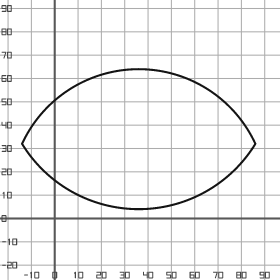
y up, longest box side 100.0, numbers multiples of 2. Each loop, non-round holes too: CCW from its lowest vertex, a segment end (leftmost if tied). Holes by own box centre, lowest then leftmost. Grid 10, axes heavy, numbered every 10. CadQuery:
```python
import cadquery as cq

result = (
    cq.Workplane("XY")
    .moveTo(-14.0, 32.0)
    .threePointArc((36.0, 4.0), (86.0, 32.0))
    .threePointArc((36.0, 64.0), (-14.0, 32.0))
    .close()
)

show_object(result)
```